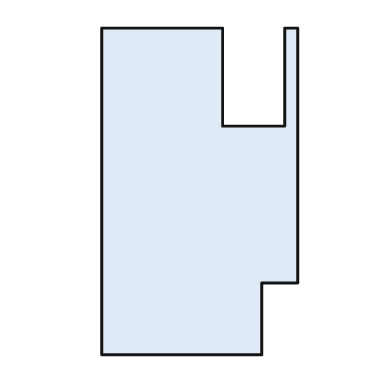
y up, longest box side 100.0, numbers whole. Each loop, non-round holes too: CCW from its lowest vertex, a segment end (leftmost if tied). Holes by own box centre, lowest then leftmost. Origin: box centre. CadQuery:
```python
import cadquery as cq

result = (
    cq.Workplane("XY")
    .moveTo(-30.0, -50.0)
    .lineTo(19.0, -50.0)
    .lineTo(19.0, -28.0)
    .lineTo(30.0, -28.0)
    .lineTo(30.0, 50.0)
    .lineTo(26.0, 50.0)
    .lineTo(26.0, 20.0)
    .lineTo(7.0, 20.0)
    .lineTo(7.0, 50.0)
    .lineTo(-30.0, 50.0)
    .close()
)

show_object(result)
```